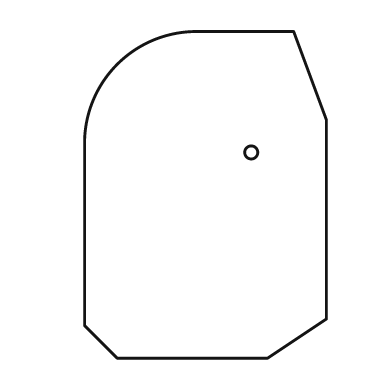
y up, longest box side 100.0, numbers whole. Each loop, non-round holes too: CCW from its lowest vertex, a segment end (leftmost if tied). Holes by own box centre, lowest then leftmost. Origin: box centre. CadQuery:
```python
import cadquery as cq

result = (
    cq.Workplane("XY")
    .moveTo(-27.0, -50.0)
    .lineTo(19.0, -50.0)
    .lineTo(37.0, -38.0)
    .lineTo(37.0, 23.0)
    .lineTo(27.0, 50.0)
    .lineTo(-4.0, 50.0)
    .threePointArc((-27.0, 40.0), (-37.0, 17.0))
    .lineTo(-37.0, -40.0)
    .close()
    .moveTo(14.0, 13.0)
    .circle(2.0)
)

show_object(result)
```